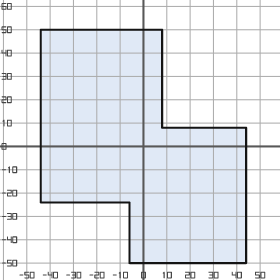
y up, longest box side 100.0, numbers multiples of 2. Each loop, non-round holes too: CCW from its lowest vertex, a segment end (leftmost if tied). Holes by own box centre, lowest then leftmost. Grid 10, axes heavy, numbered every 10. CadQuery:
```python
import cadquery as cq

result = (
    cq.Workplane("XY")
    .moveTo(-6.0, -50.0)
    .lineTo(44.0, -50.0)
    .lineTo(44.0, 8.0)
    .lineTo(8.0, 8.0)
    .lineTo(8.0, 50.0)
    .lineTo(-44.0, 50.0)
    .lineTo(-44.0, -24.0)
    .lineTo(-6.0, -24.0)
    .close()
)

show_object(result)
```